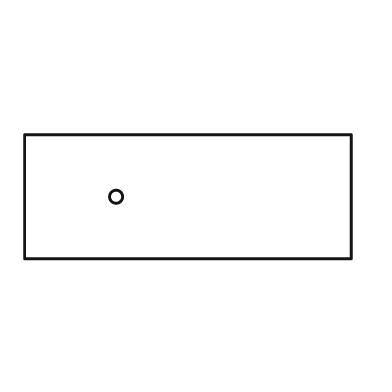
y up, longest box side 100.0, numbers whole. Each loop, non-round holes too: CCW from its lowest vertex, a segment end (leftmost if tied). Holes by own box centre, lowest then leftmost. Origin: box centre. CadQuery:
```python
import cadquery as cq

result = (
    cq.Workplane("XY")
    .moveTo(-50.0, -19.0)
    .lineTo(50.0, -19.0)
    .lineTo(50.0, 19.0)
    .lineTo(-50.0, 19.0)
    .close()
    .moveTo(-22.0, 0.0)
    .circle(2.0)
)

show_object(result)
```